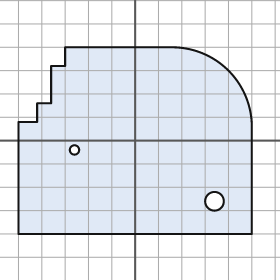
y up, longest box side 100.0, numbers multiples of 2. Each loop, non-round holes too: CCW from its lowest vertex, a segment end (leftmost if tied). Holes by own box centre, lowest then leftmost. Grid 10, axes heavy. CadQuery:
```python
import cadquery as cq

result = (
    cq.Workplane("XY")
    .moveTo(-50.0, -40.0)
    .lineTo(50.0, -40.0)
    .lineTo(50.0, 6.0)
    .threePointArc((40.0, 30.0), (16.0, 40.0))
    .lineTo(-30.0, 40.0)
    .lineTo(-30.0, 32.0)
    .lineTo(-36.0, 32.0)
    .lineTo(-36.0, 16.0)
    .lineTo(-42.0, 16.0)
    .lineTo(-42.0, 8.0)
    .lineTo(-50.0, 8.0)
    .close()
    .moveTo(34.0, -26.0)
    .circle(4.0)
    .moveTo(-26.0, -4.0)
    .circle(2.0)
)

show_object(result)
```